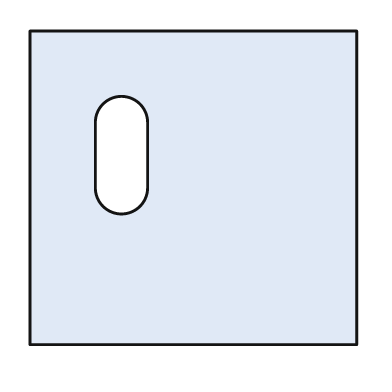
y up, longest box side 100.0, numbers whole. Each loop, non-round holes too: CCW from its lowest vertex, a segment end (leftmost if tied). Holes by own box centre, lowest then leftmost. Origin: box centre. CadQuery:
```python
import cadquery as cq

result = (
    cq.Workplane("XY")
    .moveTo(-50.0, -48.0)
    .lineTo(50.0, -48.0)
    .lineTo(50.0, 48.0)
    .lineTo(-50.0, 48.0)
    .close()
    .moveTo(-30.0, 0.0)
    .threePointArc((-22.0, -8.0), (-14.0, 0.0))
    .lineTo(-14.0, 20.0)
    .threePointArc((-22.0, 28.0), (-30.0, 20.0))
    .close()
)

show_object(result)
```